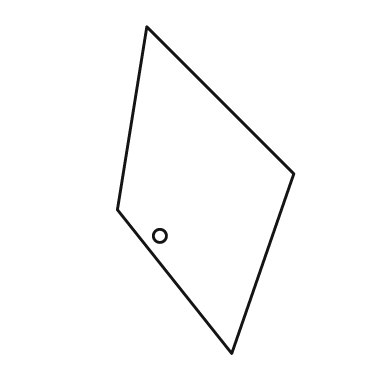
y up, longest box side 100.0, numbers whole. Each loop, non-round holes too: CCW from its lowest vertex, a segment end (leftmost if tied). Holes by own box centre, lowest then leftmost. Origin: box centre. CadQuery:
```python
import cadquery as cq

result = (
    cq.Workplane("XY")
    .moveTo(8.0, -50.0)
    .lineTo(27.0, 5.0)
    .lineTo(-18.0, 50.0)
    .lineTo(-27.0, -6.0)
    .close()
    .moveTo(-14.0, -14.0)
    .circle(2.0)
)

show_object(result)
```